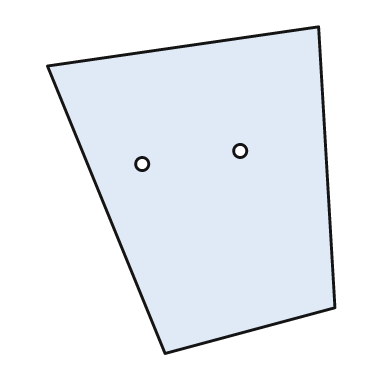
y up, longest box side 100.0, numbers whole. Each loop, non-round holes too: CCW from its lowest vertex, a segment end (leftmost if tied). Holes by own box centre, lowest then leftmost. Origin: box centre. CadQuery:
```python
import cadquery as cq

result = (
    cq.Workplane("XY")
    .moveTo(-8.0, -50.0)
    .lineTo(44.0, -36.0)
    .lineTo(39.0, 50.0)
    .lineTo(-44.0, 38.0)
    .close()
    .moveTo(-15.0, 8.0)
    .circle(2.0)
    .moveTo(15.0, 12.0)
    .circle(2.0)
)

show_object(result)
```